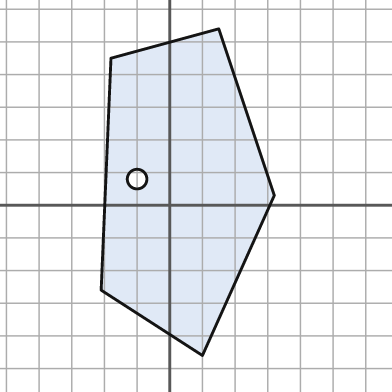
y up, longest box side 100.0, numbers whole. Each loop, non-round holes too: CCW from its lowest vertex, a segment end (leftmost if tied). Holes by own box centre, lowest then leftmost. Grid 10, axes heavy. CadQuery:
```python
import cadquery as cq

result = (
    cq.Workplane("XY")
    .moveTo(10.0, -46.0)
    .lineTo(32.0, 3.0)
    .lineTo(15.0, 54.0)
    .lineTo(-18.0, 45.0)
    .lineTo(-21.0, -26.0)
    .close()
    .moveTo(-10.0, 8.0)
    .circle(3.0)
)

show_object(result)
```